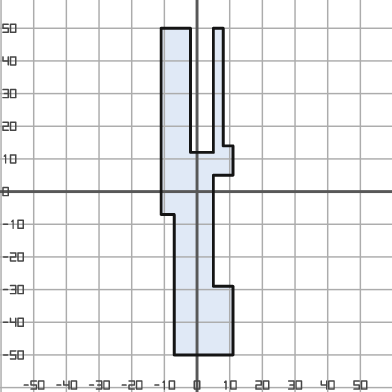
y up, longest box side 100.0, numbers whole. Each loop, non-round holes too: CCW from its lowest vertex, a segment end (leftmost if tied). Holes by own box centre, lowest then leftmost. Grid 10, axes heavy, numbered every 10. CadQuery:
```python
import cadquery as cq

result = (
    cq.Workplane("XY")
    .moveTo(-7.0, -50.0)
    .lineTo(11.0, -50.0)
    .lineTo(11.0, -29.0)
    .lineTo(5.0, -29.0)
    .lineTo(5.0, 5.0)
    .lineTo(11.0, 5.0)
    .lineTo(11.0, 14.0)
    .lineTo(8.0, 14.0)
    .lineTo(8.0, 50.0)
    .lineTo(5.0, 50.0)
    .lineTo(5.0, 12.0)
    .lineTo(-2.0, 12.0)
    .lineTo(-2.0, 50.0)
    .lineTo(-11.0, 50.0)
    .lineTo(-11.0, -7.0)
    .lineTo(-7.0, -7.0)
    .close()
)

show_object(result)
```